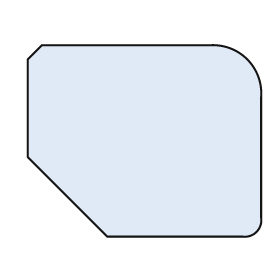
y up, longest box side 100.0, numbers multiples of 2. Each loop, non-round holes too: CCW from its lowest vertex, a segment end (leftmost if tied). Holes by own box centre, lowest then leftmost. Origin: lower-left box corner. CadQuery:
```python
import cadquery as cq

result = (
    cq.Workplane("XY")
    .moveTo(34.0, 0.0)
    .lineTo(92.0, 0.0)
    .threePointArc((98.0, 2.0), (100.0, 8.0))
    .lineTo(100.0, 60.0)
    .threePointArc((94.0, 76.0), (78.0, 82.0))
    .lineTo(6.0, 82.0)
    .lineTo(0.0, 76.0)
    .lineTo(0.0, 34.0)
    .close()
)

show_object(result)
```